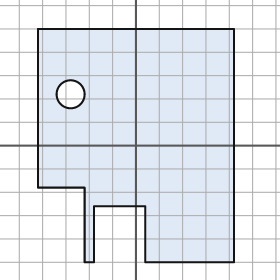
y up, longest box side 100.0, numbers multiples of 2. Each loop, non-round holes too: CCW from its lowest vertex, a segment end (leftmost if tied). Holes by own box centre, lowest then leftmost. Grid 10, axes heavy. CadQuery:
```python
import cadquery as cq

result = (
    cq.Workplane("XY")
    .moveTo(-22.0, -50.0)
    .lineTo(-18.0, -50.0)
    .lineTo(-18.0, -26.0)
    .lineTo(4.0, -26.0)
    .lineTo(4.0, -50.0)
    .lineTo(42.0, -50.0)
    .lineTo(42.0, 50.0)
    .lineTo(-42.0, 50.0)
    .lineTo(-42.0, -18.0)
    .lineTo(-22.0, -18.0)
    .close()
    .moveTo(-28.0, 22.0)
    .circle(6.0)
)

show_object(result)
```